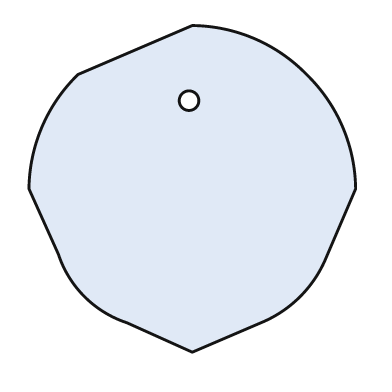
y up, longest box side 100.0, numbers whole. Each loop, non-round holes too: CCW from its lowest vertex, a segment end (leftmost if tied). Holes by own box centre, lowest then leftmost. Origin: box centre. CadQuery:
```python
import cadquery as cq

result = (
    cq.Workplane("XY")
    .moveTo(0.0, -50.0)
    .lineTo(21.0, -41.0)
    .threePointArc((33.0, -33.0), (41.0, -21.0))
    .lineTo(50.0, 0.0)
    .threePointArc((46.0, 19.0), (35.0, 35.0))
    .threePointArc((19.0, 46.0), (0.0, 50.0))
    .lineTo(-35.0, 35.0)
    .threePointArc((-46.0, 19.0), (-50.0, 0.0))
    .lineTo(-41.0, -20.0)
    .threePointArc((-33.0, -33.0), (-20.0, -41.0))
    .close()
    .moveTo(-1.0, 27.0)
    .circle(3.0)
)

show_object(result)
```